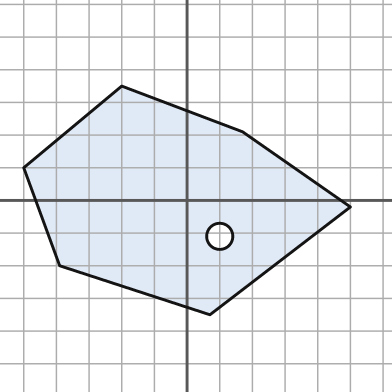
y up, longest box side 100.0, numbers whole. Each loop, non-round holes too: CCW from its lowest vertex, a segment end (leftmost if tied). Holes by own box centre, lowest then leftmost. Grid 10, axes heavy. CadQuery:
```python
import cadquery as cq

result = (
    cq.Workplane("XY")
    .moveTo(7.0, -35.0)
    .lineTo(50.0, -2.0)
    .lineTo(17.0, 21.0)
    .lineTo(-20.0, 35.0)
    .lineTo(-50.0, 10.0)
    .lineTo(-39.0, -20.0)
    .close()
    .moveTo(10.0, -11.0)
    .circle(4.0)
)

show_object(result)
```